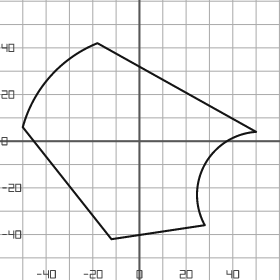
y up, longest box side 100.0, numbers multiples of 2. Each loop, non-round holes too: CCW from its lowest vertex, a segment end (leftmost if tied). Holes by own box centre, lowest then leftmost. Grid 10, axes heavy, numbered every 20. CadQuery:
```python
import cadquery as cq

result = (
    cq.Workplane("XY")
    .moveTo(-12.0, -42.0)
    .lineTo(28.0, -36.0)
    .threePointArc((28.0, -10.0), (50.0, 4.0))
    .lineTo(-18.0, 42.0)
    .threePointArc((-38.0, 28.0), (-50.0, 6.0))
    .close()
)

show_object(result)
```